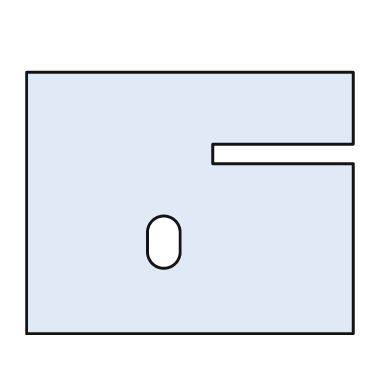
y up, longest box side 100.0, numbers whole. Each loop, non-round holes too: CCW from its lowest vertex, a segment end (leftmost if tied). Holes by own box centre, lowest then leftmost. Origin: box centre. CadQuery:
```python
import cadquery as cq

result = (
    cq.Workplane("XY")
    .moveTo(-50.0, -40.0)
    .lineTo(50.0, -40.0)
    .lineTo(50.0, 12.0)
    .lineTo(7.0, 12.0)
    .lineTo(7.0, 18.0)
    .lineTo(50.0, 18.0)
    .lineTo(50.0, 40.0)
    .lineTo(-50.0, 40.0)
    .close()
    .moveTo(-13.0, -15.0)
    .threePointArc((-8.0, -20.0), (-3.0, -15.0))
    .lineTo(-3.0, -9.0)
    .threePointArc((-8.0, -4.0), (-13.0, -9.0))
    .close()
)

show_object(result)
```